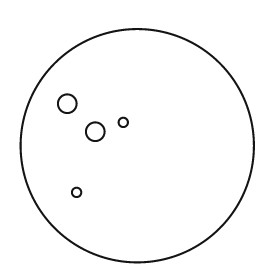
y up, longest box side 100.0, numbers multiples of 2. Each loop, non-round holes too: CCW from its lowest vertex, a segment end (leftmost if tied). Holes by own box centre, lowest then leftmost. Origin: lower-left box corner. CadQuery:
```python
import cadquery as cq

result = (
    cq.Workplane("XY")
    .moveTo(50.0, 50.0)
    .circle(50.0)
    .moveTo(24.0, 30.0)
    .circle(2.0)
    .moveTo(32.0, 56.0)
    .circle(4.0)
    .moveTo(44.0, 60.0)
    .circle(2.0)
    .moveTo(20.0, 68.0)
    .circle(4.0)
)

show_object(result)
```